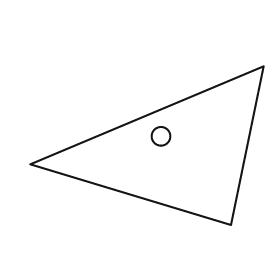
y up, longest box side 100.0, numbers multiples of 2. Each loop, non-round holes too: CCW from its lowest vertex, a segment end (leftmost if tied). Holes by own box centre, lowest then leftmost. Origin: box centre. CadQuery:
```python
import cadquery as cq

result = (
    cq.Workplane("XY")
    .moveTo(36.0, -34.0)
    .lineTo(50.0, 34.0)
    .lineTo(-50.0, -8.0)
    .close()
    .moveTo(6.0, 4.0)
    .circle(4.0)
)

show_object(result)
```